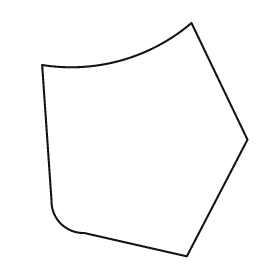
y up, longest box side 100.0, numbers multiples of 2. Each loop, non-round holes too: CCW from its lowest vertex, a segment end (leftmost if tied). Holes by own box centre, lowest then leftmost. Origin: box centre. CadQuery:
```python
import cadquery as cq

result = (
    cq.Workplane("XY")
    .moveTo(18.0, -50.0)
    .lineTo(44.0, 0.0)
    .lineTo(20.0, 50.0)
    .threePointArc((-10.0, 34.0), (-44.0, 32.0))
    .lineTo(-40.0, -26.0)
    .threePointArc((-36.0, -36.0), (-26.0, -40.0))
    .close()
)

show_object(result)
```